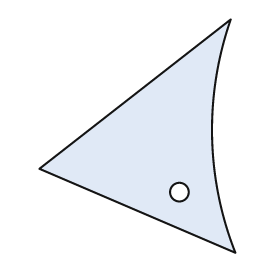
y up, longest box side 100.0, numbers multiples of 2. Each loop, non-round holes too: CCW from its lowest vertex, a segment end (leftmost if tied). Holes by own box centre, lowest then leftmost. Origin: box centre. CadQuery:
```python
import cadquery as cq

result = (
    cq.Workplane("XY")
    .moveTo(42.0, -50.0)
    .threePointArc((32.0, 0.0), (40.0, 50.0))
    .lineTo(-42.0, -14.0)
    .close()
    .moveTo(18.0, -24.0)
    .circle(4.0)
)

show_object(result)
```